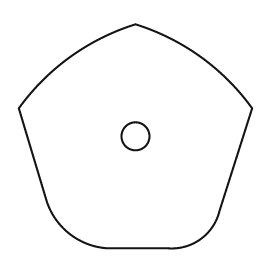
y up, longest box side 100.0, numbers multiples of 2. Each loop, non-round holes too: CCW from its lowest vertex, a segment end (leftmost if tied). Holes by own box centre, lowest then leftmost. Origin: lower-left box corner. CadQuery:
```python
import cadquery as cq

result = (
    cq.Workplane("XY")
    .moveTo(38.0, 0.0)
    .lineTo(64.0, 0.0)
    .threePointArc((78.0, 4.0), (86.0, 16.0))
    .lineTo(100.0, 60.0)
    .threePointArc((78.0, 82.0), (50.0, 96.0))
    .threePointArc((22.0, 82.0), (0.0, 60.0))
    .lineTo(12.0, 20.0)
    .threePointArc((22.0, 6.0), (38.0, 0.0))
    .close()
    .moveTo(50.0, 48.0)
    .circle(6.0)
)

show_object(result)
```